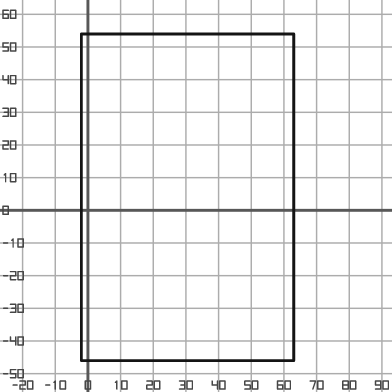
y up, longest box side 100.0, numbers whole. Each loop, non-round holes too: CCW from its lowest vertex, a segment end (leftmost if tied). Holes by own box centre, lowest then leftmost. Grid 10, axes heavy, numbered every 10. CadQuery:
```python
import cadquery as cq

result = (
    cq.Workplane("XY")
    .moveTo(-2.0, -46.0)
    .lineTo(63.0, -46.0)
    .lineTo(63.0, 54.0)
    .lineTo(-2.0, 54.0)
    .close()
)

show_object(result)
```